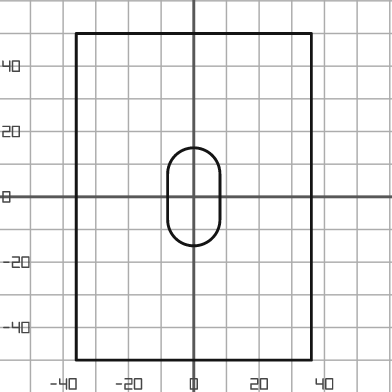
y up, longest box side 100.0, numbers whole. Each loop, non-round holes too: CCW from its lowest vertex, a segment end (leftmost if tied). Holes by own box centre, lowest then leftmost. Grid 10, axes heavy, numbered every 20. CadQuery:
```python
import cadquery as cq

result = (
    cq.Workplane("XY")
    .moveTo(-36.0, -50.0)
    .lineTo(36.0, -50.0)
    .lineTo(36.0, 50.0)
    .lineTo(-36.0, 50.0)
    .close()
    .moveTo(-8.0, -7.0)
    .threePointArc((0.0, -15.0), (8.0, -7.0))
    .lineTo(8.0, 7.0)
    .threePointArc((0.0, 15.0), (-8.0, 7.0))
    .close()
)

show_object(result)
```